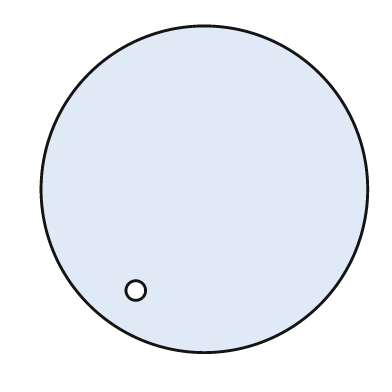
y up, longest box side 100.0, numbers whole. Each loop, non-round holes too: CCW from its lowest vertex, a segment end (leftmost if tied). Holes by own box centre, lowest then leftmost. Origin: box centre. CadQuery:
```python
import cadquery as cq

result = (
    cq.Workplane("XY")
    .moveTo(0.0, 0.0)
    .circle(50.0)
    .moveTo(-21.0, -31.0)
    .circle(3.0)
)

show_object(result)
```